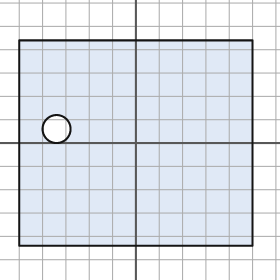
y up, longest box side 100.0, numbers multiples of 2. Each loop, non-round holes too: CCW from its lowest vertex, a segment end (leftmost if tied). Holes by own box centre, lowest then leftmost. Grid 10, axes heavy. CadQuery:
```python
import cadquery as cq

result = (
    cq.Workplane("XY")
    .moveTo(-50.0, -44.0)
    .lineTo(50.0, -44.0)
    .lineTo(50.0, 44.0)
    .lineTo(-50.0, 44.0)
    .close()
    .moveTo(-34.0, 6.0)
    .circle(6.0)
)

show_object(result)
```